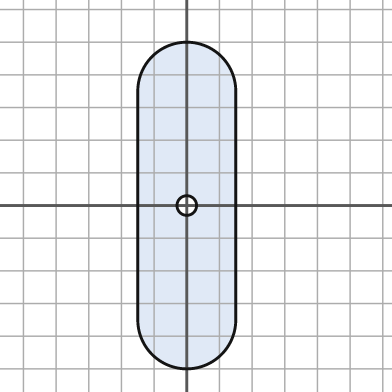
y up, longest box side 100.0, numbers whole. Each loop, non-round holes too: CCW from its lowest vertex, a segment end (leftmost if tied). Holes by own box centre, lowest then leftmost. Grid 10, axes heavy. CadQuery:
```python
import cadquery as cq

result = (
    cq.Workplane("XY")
    .moveTo(-15.0, -35.0)
    .threePointArc((0.0, -50.0), (15.0, -35.0))
    .lineTo(15.0, 35.0)
    .threePointArc((0.0, 50.0), (-15.0, 35.0))
    .close()
    .moveTo(0.0, 0.0)
    .circle(3.0)
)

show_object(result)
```